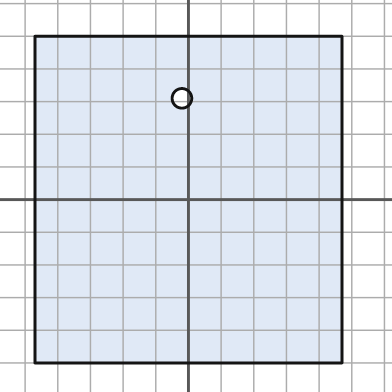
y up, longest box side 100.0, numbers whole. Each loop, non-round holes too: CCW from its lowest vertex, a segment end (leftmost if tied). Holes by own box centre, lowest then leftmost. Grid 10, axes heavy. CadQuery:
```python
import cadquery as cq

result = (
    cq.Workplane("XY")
    .moveTo(-47.0, -50.0)
    .lineTo(47.0, -50.0)
    .lineTo(47.0, 50.0)
    .lineTo(-47.0, 50.0)
    .close()
    .moveTo(-2.0, 31.0)
    .circle(3.0)
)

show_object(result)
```